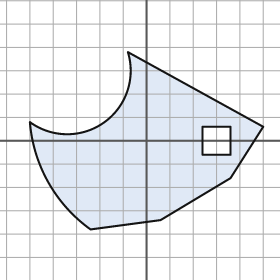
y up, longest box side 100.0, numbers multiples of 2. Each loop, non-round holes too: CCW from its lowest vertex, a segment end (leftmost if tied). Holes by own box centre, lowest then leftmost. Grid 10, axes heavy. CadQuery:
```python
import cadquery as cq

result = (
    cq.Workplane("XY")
    .moveTo(-24.0, -38.0)
    .lineTo(6.0, -34.0)
    .lineTo(36.0, -16.0)
    .lineTo(50.0, 6.0)
    .lineTo(-8.0, 38.0)
    .threePointArc((-18.0, 8.0), (-50.0, 8.0))
    .threePointArc((-42.0, -18.0), (-24.0, -38.0))
    .close()
    .moveTo(24.0, -6.0)
    .lineTo(36.0, -6.0)
    .lineTo(36.0, 6.0)
    .lineTo(24.0, 6.0)
    .close()
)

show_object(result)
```